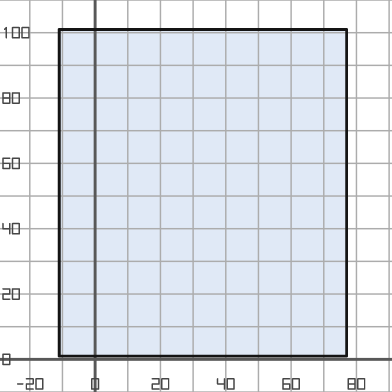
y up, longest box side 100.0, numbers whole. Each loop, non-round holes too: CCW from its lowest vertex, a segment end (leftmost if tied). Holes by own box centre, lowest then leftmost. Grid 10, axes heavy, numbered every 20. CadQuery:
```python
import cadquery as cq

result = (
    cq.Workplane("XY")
    .moveTo(-11.0, 1.0)
    .lineTo(77.0, 1.0)
    .lineTo(77.0, 101.0)
    .lineTo(-11.0, 101.0)
    .close()
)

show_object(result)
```